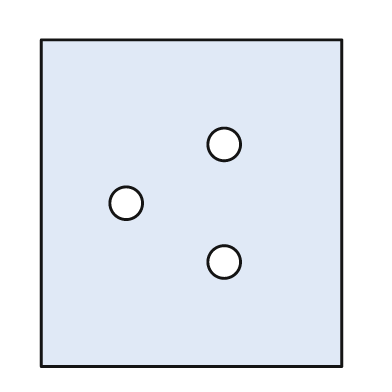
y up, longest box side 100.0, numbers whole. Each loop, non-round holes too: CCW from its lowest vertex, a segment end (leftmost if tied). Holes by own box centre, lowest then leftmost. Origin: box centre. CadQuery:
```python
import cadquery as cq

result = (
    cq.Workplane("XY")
    .moveTo(-46.0, -50.0)
    .lineTo(46.0, -50.0)
    .lineTo(46.0, 50.0)
    .lineTo(-46.0, 50.0)
    .close()
    .moveTo(10.0, -18.0)
    .circle(5.0)
    .moveTo(-20.0, 0.0)
    .circle(5.0)
    .moveTo(10.0, 18.0)
    .circle(5.0)
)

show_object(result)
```